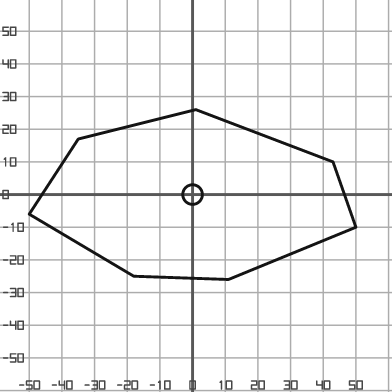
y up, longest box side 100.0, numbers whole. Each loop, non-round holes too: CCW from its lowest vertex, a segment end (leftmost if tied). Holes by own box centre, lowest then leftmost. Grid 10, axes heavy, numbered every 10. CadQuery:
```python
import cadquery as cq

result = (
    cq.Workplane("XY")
    .moveTo(11.0, -26.0)
    .lineTo(50.0, -10.0)
    .lineTo(43.0, 10.0)
    .lineTo(1.0, 26.0)
    .lineTo(-35.0, 17.0)
    .lineTo(-50.0, -6.0)
    .lineTo(-18.0, -25.0)
    .close()
    .moveTo(0.0, 0.0)
    .circle(3.0)
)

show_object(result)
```